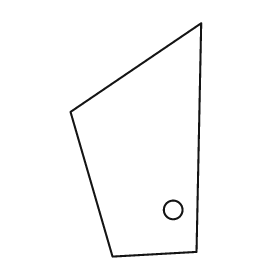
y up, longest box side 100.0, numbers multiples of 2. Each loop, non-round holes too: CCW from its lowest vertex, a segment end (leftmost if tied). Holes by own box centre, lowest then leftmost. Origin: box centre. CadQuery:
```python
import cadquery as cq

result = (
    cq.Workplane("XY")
    .moveTo(-10.0, -50.0)
    .lineTo(26.0, -48.0)
    .lineTo(28.0, 50.0)
    .lineTo(-28.0, 12.0)
    .close()
    .moveTo(16.0, -30.0)
    .circle(4.0)
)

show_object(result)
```